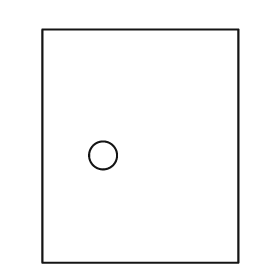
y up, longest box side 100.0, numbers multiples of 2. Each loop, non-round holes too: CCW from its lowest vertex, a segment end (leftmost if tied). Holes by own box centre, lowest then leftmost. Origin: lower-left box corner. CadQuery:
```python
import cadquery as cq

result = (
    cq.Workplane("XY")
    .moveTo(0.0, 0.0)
    .lineTo(84.0, 0.0)
    .lineTo(84.0, 100.0)
    .lineTo(0.0, 100.0)
    .close()
    .moveTo(26.0, 46.0)
    .circle(6.0)
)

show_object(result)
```